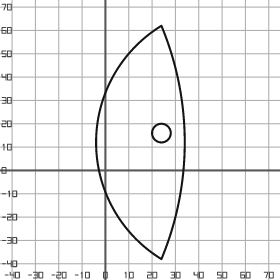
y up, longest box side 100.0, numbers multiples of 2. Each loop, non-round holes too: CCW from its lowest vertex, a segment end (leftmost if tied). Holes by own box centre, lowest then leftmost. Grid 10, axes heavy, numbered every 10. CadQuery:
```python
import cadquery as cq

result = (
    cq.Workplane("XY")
    .moveTo(24.0, -38.0)
    .threePointArc((34.0, 12.0), (24.0, 62.0))
    .threePointArc((-4.0, 12.0), (24.0, -38.0))
    .close()
    .moveTo(24.0, 16.0)
    .circle(4.0)
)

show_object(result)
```